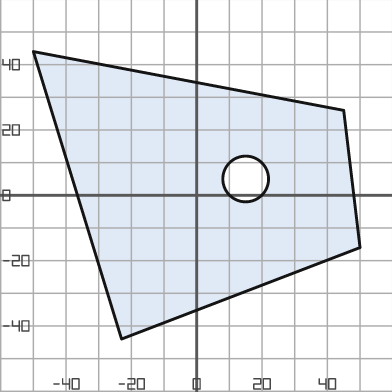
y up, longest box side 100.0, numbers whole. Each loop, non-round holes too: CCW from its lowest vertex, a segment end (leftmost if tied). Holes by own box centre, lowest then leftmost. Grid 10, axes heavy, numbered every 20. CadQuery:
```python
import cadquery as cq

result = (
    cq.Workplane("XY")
    .moveTo(-23.0, -44.0)
    .lineTo(50.0, -16.0)
    .lineTo(45.0, 26.0)
    .lineTo(-50.0, 44.0)
    .close()
    .moveTo(15.0, 5.0)
    .circle(7.0)
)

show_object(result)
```